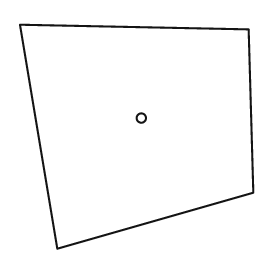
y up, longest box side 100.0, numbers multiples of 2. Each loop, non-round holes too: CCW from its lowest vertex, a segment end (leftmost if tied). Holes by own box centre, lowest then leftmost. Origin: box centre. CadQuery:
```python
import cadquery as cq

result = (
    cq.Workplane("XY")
    .moveTo(-34.0, -48.0)
    .lineTo(50.0, -24.0)
    .lineTo(48.0, 46.0)
    .lineTo(-50.0, 48.0)
    .close()
    .moveTo(2.0, 8.0)
    .circle(2.0)
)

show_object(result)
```